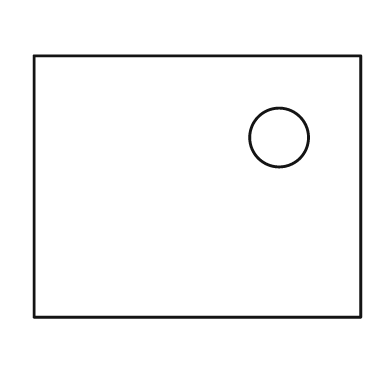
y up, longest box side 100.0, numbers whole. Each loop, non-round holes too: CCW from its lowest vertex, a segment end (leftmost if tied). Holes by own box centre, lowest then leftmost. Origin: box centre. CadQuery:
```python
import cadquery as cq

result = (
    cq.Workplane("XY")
    .moveTo(-50.0, -40.0)
    .lineTo(50.0, -40.0)
    .lineTo(50.0, 40.0)
    .lineTo(-50.0, 40.0)
    .close()
    .moveTo(25.0, 15.0)
    .circle(9.0)
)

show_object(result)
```